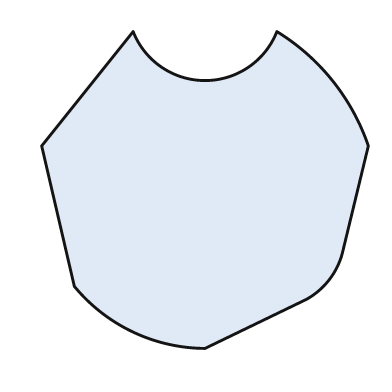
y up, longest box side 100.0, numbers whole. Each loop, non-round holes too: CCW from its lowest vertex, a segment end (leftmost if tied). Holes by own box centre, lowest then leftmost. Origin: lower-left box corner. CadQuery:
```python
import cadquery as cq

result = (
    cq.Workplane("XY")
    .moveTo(50.0, 0.0)
    .lineTo(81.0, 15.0)
    .threePointArc((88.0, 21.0), (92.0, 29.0))
    .lineTo(100.0, 62.0)
    .threePointArc((89.0, 82.0), (72.0, 97.0))
    .threePointArc((50.0, 82.0), (28.0, 97.0))
    .lineTo(0.0, 62.0)
    .lineTo(10.0, 19.0)
    .threePointArc((28.0, 5.0), (50.0, 0.0))
    .close()
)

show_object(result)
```